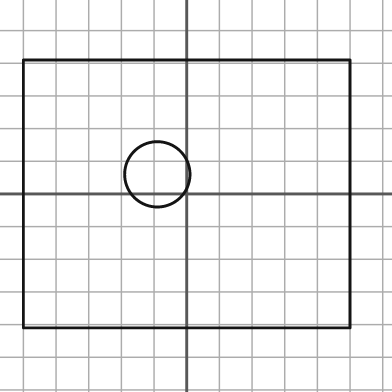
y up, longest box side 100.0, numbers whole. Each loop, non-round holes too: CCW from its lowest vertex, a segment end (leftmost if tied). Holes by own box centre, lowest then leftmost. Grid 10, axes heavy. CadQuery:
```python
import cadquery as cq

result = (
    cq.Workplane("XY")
    .moveTo(-50.0, -41.0)
    .lineTo(50.0, -41.0)
    .lineTo(50.0, 41.0)
    .lineTo(-50.0, 41.0)
    .close()
    .moveTo(-9.0, 6.0)
    .circle(10.0)
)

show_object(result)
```